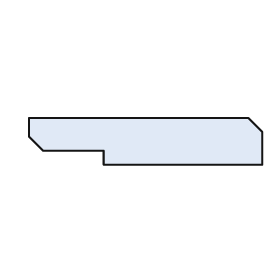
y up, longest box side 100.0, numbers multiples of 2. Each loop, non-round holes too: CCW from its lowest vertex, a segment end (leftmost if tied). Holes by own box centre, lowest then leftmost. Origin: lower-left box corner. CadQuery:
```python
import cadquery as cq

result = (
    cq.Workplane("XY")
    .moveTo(32.0, 0.0)
    .lineTo(100.0, 0.0)
    .lineTo(100.0, 14.0)
    .lineTo(94.0, 20.0)
    .lineTo(0.0, 20.0)
    .lineTo(0.0, 12.0)
    .lineTo(6.0, 6.0)
    .lineTo(32.0, 6.0)
    .close()
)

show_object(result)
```